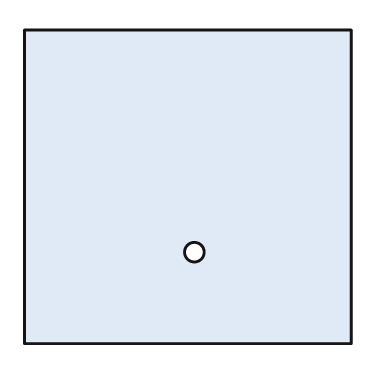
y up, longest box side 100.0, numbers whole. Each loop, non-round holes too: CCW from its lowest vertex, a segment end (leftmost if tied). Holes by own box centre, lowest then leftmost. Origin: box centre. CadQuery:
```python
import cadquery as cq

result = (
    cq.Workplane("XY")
    .moveTo(-50.0, -48.0)
    .lineTo(50.0, -48.0)
    .lineTo(50.0, 48.0)
    .lineTo(-50.0, 48.0)
    .close()
    .moveTo(2.0, -20.0)
    .circle(3.0)
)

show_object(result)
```